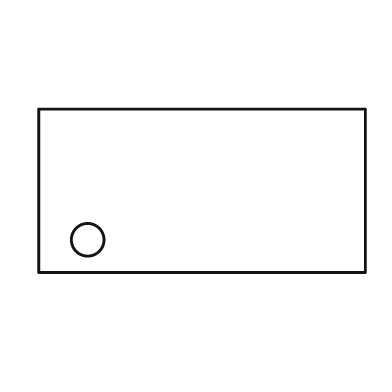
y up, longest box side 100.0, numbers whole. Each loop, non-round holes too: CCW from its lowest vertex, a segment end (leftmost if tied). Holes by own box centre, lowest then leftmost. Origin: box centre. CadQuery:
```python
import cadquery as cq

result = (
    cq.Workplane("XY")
    .moveTo(-50.0, -25.0)
    .lineTo(50.0, -25.0)
    .lineTo(50.0, 25.0)
    .lineTo(-50.0, 25.0)
    .close()
    .moveTo(-35.0, -15.0)
    .circle(5.0)
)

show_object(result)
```